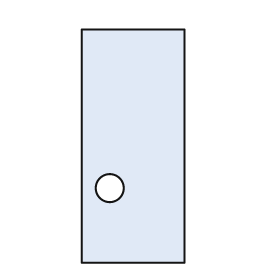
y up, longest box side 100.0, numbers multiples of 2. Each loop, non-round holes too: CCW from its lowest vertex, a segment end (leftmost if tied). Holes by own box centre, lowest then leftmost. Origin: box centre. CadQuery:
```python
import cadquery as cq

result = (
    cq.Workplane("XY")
    .moveTo(-22.0, -50.0)
    .lineTo(22.0, -50.0)
    .lineTo(22.0, 50.0)
    .lineTo(-22.0, 50.0)
    .close()
    .moveTo(-10.0, -18.0)
    .circle(6.0)
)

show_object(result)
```